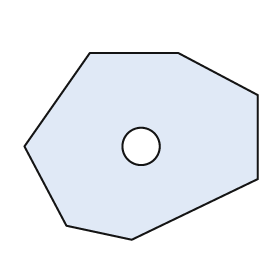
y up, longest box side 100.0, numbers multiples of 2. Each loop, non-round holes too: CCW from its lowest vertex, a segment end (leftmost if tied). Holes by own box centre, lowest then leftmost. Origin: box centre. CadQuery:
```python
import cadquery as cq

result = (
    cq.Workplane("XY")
    .moveTo(-4.0, -40.0)
    .lineTo(50.0, -14.0)
    .lineTo(50.0, 22.0)
    .lineTo(16.0, 40.0)
    .lineTo(-22.0, 40.0)
    .lineTo(-50.0, 0.0)
    .lineTo(-32.0, -34.0)
    .close()
    .moveTo(0.0, 0.0)
    .circle(8.0)
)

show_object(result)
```